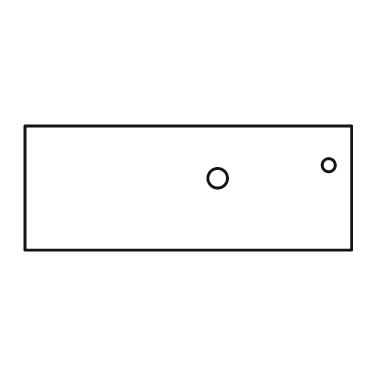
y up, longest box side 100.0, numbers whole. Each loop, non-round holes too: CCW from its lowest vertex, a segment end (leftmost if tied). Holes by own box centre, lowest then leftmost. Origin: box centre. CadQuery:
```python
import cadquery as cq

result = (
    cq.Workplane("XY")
    .moveTo(-50.0, -19.0)
    .lineTo(50.0, -19.0)
    .lineTo(50.0, 19.0)
    .lineTo(-50.0, 19.0)
    .close()
    .moveTo(9.0, 3.0)
    .circle(3.0)
    .moveTo(43.0, 7.0)
    .circle(2.0)
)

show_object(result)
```